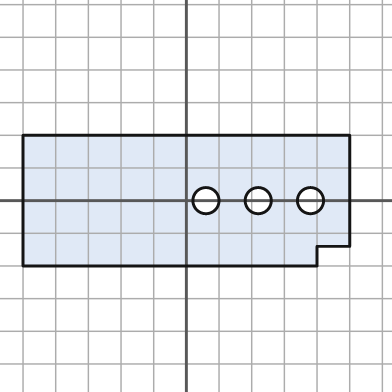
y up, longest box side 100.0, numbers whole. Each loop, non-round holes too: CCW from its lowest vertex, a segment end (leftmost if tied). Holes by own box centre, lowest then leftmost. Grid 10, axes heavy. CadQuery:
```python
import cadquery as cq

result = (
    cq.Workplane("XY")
    .moveTo(-50.0, -20.0)
    .lineTo(40.0, -20.0)
    .lineTo(40.0, -14.0)
    .lineTo(50.0, -14.0)
    .lineTo(50.0, 20.0)
    .lineTo(-50.0, 20.0)
    .close()
    .moveTo(6.0, 0.0)
    .circle(4.0)
    .moveTo(22.0, 0.0)
    .circle(4.0)
    .moveTo(38.0, 0.0)
    .circle(4.0)
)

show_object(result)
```